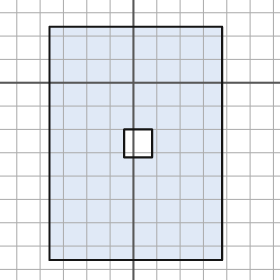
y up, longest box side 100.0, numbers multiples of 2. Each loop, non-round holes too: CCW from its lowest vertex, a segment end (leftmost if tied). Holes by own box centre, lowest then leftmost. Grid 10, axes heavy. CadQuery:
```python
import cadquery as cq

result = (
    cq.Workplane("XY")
    .moveTo(-36.0, -76.0)
    .lineTo(38.0, -76.0)
    .lineTo(38.0, 24.0)
    .lineTo(-36.0, 24.0)
    .close()
    .moveTo(-4.0, -32.0)
    .lineTo(8.0, -32.0)
    .lineTo(8.0, -20.0)
    .lineTo(-4.0, -20.0)
    .close()
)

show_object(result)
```